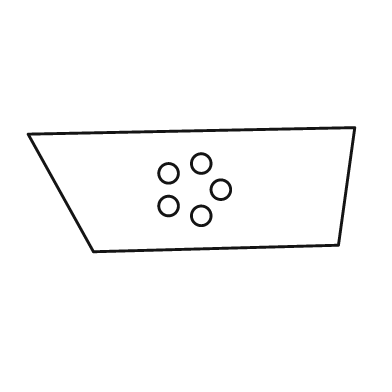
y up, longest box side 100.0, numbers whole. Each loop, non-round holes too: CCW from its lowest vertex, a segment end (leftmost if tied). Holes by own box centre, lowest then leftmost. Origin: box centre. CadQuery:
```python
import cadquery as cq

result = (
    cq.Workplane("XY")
    .moveTo(-30.0, -19.0)
    .lineTo(45.0, -17.0)
    .lineTo(50.0, 19.0)
    .lineTo(-50.0, 17.0)
    .close()
    .moveTo(3.0, -8.0)
    .circle(3.0)
    .moveTo(-7.0, -5.0)
    .circle(3.0)
    .moveTo(9.0, 0.0)
    .circle(3.0)
    .moveTo(-7.0, 5.0)
    .circle(3.0)
    .moveTo(3.0, 8.0)
    .circle(3.0)
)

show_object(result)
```